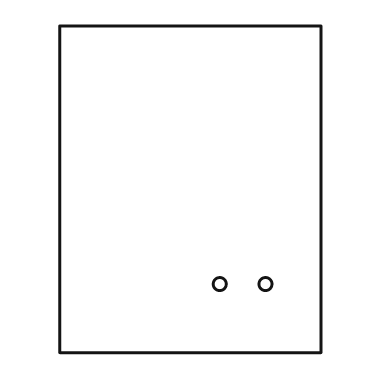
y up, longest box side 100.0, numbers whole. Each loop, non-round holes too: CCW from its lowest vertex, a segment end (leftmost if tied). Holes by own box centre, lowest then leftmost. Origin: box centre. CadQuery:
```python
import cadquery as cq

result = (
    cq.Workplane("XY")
    .moveTo(-40.0, -50.0)
    .lineTo(40.0, -50.0)
    .lineTo(40.0, 50.0)
    .lineTo(-40.0, 50.0)
    .close()
    .moveTo(9.0, -29.0)
    .circle(2.0)
    .moveTo(23.0, -29.0)
    .circle(2.0)
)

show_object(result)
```